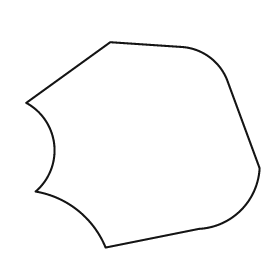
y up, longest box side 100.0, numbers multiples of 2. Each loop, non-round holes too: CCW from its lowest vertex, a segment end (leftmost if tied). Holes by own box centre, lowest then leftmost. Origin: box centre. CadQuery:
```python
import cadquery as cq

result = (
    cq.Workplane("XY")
    .moveTo(-16.0, -44.0)
    .lineTo(24.0, -36.0)
    .threePointArc((42.0, -28.0), (50.0, -10.0))
    .lineTo(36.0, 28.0)
    .threePointArc((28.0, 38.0), (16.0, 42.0))
    .lineTo(-14.0, 44.0)
    .lineTo(-50.0, 18.0)
    .threePointArc((-38.0, 0.0), (-46.0, -20.0))
    .threePointArc((-28.0, -28.0), (-16.0, -44.0))
    .close()
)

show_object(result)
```